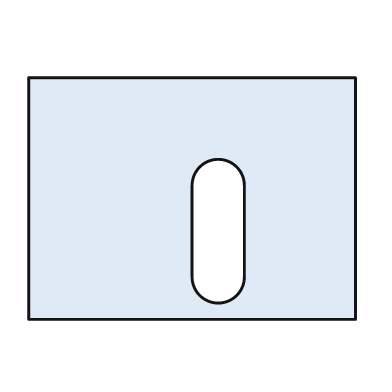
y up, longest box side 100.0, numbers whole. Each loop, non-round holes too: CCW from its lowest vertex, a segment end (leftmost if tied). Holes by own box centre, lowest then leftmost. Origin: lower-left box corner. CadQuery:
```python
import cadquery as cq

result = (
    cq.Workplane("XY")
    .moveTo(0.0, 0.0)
    .lineTo(100.0, 0.0)
    .lineTo(100.0, 74.0)
    .lineTo(0.0, 74.0)
    .close()
    .moveTo(50.0, 13.0)
    .threePointArc((58.0, 5.0), (66.0, 13.0))
    .lineTo(66.0, 41.0)
    .threePointArc((58.0, 49.0), (50.0, 41.0))
    .close()
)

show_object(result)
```